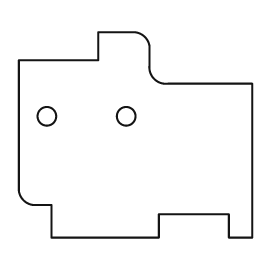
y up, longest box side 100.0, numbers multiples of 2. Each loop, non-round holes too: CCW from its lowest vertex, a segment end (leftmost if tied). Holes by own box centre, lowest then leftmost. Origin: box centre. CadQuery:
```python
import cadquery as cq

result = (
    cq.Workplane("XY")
    .moveTo(-36.0, -44.0)
    .lineTo(10.0, -44.0)
    .lineTo(10.0, -34.0)
    .lineTo(40.0, -34.0)
    .lineTo(40.0, -44.0)
    .lineTo(50.0, -44.0)
    .lineTo(50.0, 22.0)
    .lineTo(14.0, 22.0)
    .threePointArc((8.0, 24.0), (6.0, 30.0))
    .lineTo(6.0, 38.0)
    .threePointArc((4.0, 42.0), (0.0, 44.0))
    .lineTo(-16.0, 44.0)
    .lineTo(-16.0, 32.0)
    .lineTo(-50.0, 32.0)
    .lineTo(-50.0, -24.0)
    .threePointArc((-48.0, -28.0), (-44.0, -30.0))
    .lineTo(-36.0, -30.0)
    .close()
    .moveTo(-38.0, 8.0)
    .circle(4.0)
    .moveTo(-4.0, 8.0)
    .circle(4.0)
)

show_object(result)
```